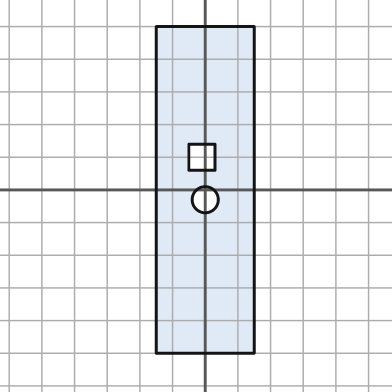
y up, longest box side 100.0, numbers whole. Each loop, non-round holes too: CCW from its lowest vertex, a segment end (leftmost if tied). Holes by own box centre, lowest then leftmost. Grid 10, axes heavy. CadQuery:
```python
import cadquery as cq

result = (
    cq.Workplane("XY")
    .moveTo(-15.0, -50.0)
    .lineTo(15.0, -50.0)
    .lineTo(15.0, 50.0)
    .lineTo(-15.0, 50.0)
    .close()
    .moveTo(0.0, -3.0)
    .circle(4.0)
    .moveTo(-5.0, 6.0)
    .lineTo(3.0, 6.0)
    .lineTo(3.0, 14.0)
    .lineTo(-5.0, 14.0)
    .close()
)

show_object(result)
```